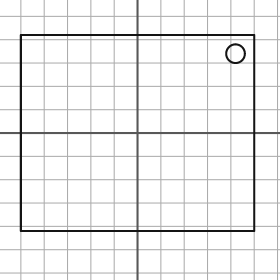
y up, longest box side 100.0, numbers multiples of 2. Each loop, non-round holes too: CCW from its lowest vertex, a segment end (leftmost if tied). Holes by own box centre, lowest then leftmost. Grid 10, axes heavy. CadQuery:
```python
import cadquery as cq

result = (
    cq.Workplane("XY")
    .moveTo(-50.0, -42.0)
    .lineTo(50.0, -42.0)
    .lineTo(50.0, 42.0)
    .lineTo(-50.0, 42.0)
    .close()
    .moveTo(42.0, 34.0)
    .circle(4.0)
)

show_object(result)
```